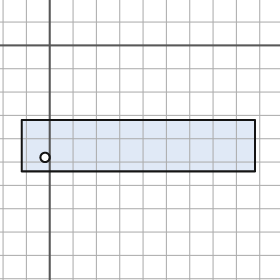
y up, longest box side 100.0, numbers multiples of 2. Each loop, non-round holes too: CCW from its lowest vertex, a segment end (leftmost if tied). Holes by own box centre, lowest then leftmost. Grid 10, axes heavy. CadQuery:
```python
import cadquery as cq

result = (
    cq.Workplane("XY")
    .moveTo(-12.0, -54.0)
    .lineTo(88.0, -54.0)
    .lineTo(88.0, -32.0)
    .lineTo(-12.0, -32.0)
    .close()
    .moveTo(-2.0, -48.0)
    .circle(2.0)
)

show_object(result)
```